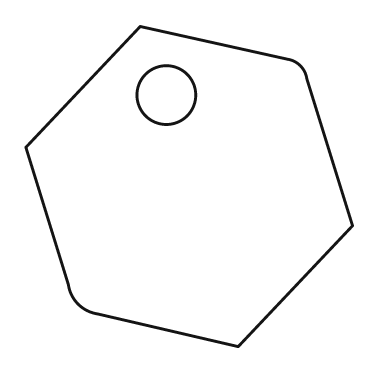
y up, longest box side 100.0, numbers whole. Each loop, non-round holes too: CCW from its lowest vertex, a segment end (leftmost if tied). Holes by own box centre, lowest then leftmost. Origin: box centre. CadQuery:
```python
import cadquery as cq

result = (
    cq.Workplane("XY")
    .moveTo(15.0, -49.0)
    .lineTo(50.0, -12.0)
    .lineTo(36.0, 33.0)
    .threePointArc((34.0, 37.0), (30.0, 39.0))
    .lineTo(-15.0, 49.0)
    .lineTo(-50.0, 12.0)
    .lineTo(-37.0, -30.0)
    .threePointArc((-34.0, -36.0), (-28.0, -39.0))
    .close()
    .moveTo(-7.0, 28.0)
    .circle(9.0)
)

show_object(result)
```